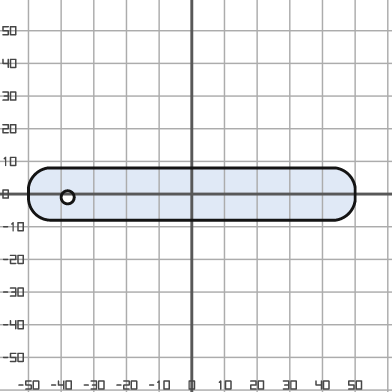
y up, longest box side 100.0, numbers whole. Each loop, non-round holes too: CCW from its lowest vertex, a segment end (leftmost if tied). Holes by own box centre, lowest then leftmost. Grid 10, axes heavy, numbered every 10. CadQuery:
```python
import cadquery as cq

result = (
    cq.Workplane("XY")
    .moveTo(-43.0, -8.0)
    .lineTo(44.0, -8.0)
    .threePointArc((48.0, -6.0), (50.0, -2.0))
    .lineTo(50.0, 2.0)
    .threePointArc((48.0, 6.0), (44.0, 8.0))
    .lineTo(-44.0, 8.0)
    .threePointArc((-48.0, 6.0), (-50.0, 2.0))
    .lineTo(-50.0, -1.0)
    .threePointArc((-48.0, -6.0), (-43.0, -8.0))
    .close()
    .moveTo(-38.0, -1.0)
    .circle(2.0)
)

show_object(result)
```